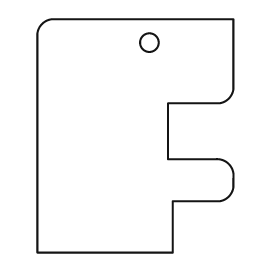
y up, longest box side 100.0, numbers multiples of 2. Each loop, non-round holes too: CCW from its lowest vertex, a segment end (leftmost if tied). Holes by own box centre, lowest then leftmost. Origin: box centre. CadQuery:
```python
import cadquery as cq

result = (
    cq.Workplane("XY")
    .moveTo(-42.0, -50.0)
    .lineTo(16.0, -50.0)
    .lineTo(16.0, -28.0)
    .lineTo(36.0, -28.0)
    .threePointArc((40.0, -26.0), (42.0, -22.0))
    .lineTo(42.0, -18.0)
    .threePointArc((40.0, -12.0), (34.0, -10.0))
    .lineTo(14.0, -10.0)
    .lineTo(14.0, 14.0)
    .lineTo(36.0, 14.0)
    .threePointArc((40.0, 16.0), (42.0, 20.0))
    .lineTo(42.0, 50.0)
    .lineTo(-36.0, 50.0)
    .threePointArc((-40.0, 48.0), (-42.0, 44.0))
    .close()
    .moveTo(6.0, 40.0)
    .circle(4.0)
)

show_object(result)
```